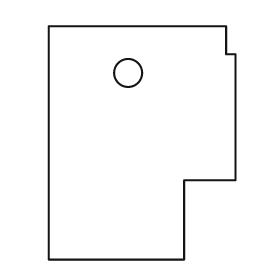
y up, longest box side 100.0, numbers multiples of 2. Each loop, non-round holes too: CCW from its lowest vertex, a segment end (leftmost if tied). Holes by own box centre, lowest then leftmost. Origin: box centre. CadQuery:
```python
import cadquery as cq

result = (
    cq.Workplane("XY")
    .moveTo(-40.0, -50.0)
    .lineTo(18.0, -50.0)
    .lineTo(18.0, -16.0)
    .lineTo(40.0, -16.0)
    .lineTo(40.0, 38.0)
    .lineTo(36.0, 38.0)
    .lineTo(36.0, 50.0)
    .lineTo(-40.0, 50.0)
    .close()
    .moveTo(-6.0, 30.0)
    .circle(6.0)
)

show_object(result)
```